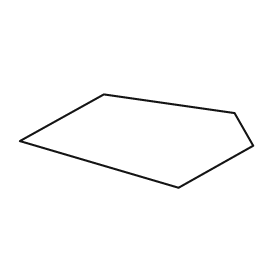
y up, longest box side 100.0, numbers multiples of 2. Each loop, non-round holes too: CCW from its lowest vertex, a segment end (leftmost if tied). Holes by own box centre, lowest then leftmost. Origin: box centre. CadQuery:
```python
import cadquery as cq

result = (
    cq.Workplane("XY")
    .moveTo(18.0, -20.0)
    .lineTo(50.0, -2.0)
    .lineTo(42.0, 12.0)
    .lineTo(-14.0, 20.0)
    .lineTo(-50.0, 0.0)
    .close()
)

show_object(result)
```